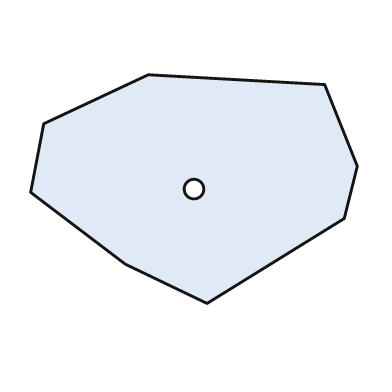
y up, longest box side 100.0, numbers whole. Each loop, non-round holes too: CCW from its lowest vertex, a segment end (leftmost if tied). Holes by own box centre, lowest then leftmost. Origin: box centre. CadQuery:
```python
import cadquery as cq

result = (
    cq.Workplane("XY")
    .moveTo(4.0, -35.0)
    .lineTo(46.0, -9.0)
    .lineTo(50.0, 7.0)
    .lineTo(40.0, 32.0)
    .lineTo(-14.0, 35.0)
    .lineTo(-46.0, 20.0)
    .lineTo(-50.0, -1.0)
    .lineTo(-21.0, -23.0)
    .close()
    .moveTo(0.0, 0.0)
    .circle(3.0)
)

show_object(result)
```